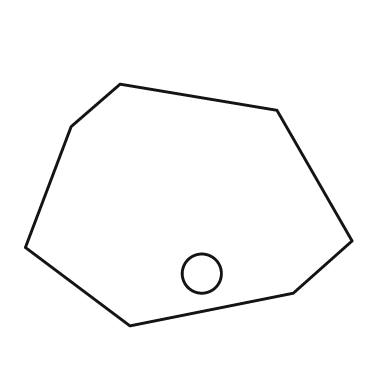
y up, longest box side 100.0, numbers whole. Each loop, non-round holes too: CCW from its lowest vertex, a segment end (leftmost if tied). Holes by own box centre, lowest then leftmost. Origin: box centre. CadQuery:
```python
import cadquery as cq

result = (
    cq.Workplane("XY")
    .moveTo(-18.0, -37.0)
    .lineTo(32.0, -27.0)
    .lineTo(50.0, -11.0)
    .lineTo(27.0, 29.0)
    .lineTo(-21.0, 37.0)
    .lineTo(-36.0, 24.0)
    .lineTo(-50.0, -13.0)
    .close()
    .moveTo(4.0, -21.0)
    .circle(6.0)
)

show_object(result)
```